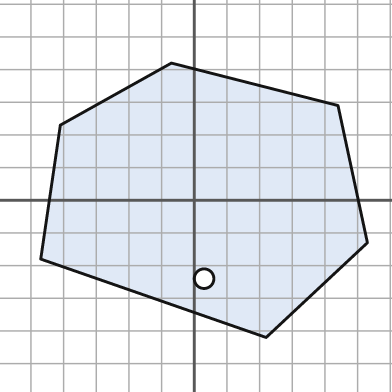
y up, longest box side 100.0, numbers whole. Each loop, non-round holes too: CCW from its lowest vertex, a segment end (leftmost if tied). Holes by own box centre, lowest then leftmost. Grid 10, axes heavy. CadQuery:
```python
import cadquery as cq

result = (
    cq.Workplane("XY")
    .moveTo(22.0, -42.0)
    .lineTo(53.0, -13.0)
    .lineTo(44.0, 29.0)
    .lineTo(-7.0, 42.0)
    .lineTo(-41.0, 23.0)
    .lineTo(-47.0, -18.0)
    .close()
    .moveTo(3.0, -24.0)
    .circle(3.0)
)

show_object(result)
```